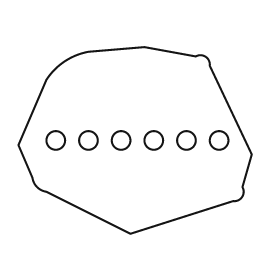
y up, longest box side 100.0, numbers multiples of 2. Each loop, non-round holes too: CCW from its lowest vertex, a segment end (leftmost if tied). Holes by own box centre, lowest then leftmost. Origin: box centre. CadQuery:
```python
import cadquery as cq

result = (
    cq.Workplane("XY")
    .moveTo(-2.0, -40.0)
    .lineTo(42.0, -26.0)
    .threePointArc((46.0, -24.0), (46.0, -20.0))
    .lineTo(50.0, -6.0)
    .lineTo(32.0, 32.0)
    .threePointArc((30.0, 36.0), (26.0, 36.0))
    .lineTo(4.0, 40.0)
    .lineTo(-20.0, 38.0)
    .threePointArc((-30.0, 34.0), (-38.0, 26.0))
    .lineTo(-50.0, -2.0)
    .lineTo(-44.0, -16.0)
    .threePointArc((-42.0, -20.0), (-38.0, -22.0))
    .close()
    .moveTo(-34.0, 0.0)
    .circle(4.0)
    .moveTo(-20.0, 0.0)
    .circle(4.0)
    .moveTo(-6.0, 0.0)
    .circle(4.0)
    .moveTo(8.0, 0.0)
    .circle(4.0)
    .moveTo(22.0, 0.0)
    .circle(4.0)
    .moveTo(36.0, 0.0)
    .circle(4.0)
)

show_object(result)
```